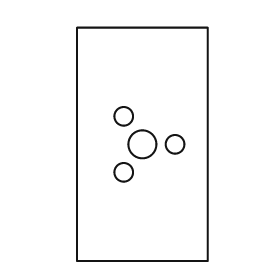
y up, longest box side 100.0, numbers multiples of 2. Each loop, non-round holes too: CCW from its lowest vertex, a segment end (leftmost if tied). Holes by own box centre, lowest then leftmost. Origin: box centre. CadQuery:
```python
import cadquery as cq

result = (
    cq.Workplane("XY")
    .moveTo(-28.0, -50.0)
    .lineTo(28.0, -50.0)
    .lineTo(28.0, 50.0)
    .lineTo(-28.0, 50.0)
    .close()
    .moveTo(-8.0, -12.0)
    .circle(4.0)
    .moveTo(0.0, 0.0)
    .circle(6.0)
    .moveTo(14.0, 0.0)
    .circle(4.0)
    .moveTo(-8.0, 12.0)
    .circle(4.0)
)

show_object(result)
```